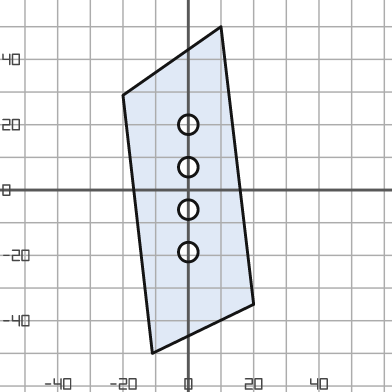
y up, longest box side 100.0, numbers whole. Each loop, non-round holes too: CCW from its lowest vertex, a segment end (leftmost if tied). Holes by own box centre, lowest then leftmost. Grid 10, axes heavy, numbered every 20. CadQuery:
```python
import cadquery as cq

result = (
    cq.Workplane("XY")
    .moveTo(-11.0, -50.0)
    .lineTo(20.0, -35.0)
    .lineTo(10.0, 50.0)
    .lineTo(-20.0, 29.0)
    .close()
    .moveTo(0.0, -19.0)
    .circle(3.0)
    .moveTo(0.0, -6.0)
    .circle(3.0)
    .moveTo(0.0, 7.0)
    .circle(3.0)
    .moveTo(0.0, 20.0)
    .circle(3.0)
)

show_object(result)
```